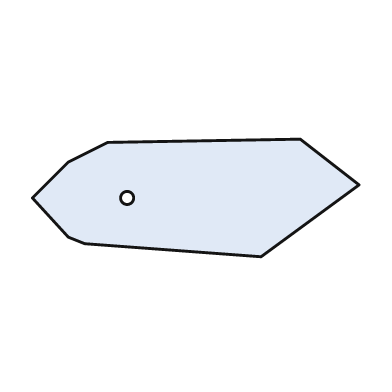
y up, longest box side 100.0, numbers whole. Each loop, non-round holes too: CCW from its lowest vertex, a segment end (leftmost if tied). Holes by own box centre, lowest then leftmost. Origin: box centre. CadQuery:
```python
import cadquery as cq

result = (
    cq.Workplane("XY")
    .moveTo(20.0, -18.0)
    .lineTo(50.0, 4.0)
    .lineTo(32.0, 18.0)
    .lineTo(-27.0, 17.0)
    .lineTo(-39.0, 11.0)
    .lineTo(-50.0, 0.0)
    .lineTo(-39.0, -12.0)
    .lineTo(-34.0, -14.0)
    .close()
    .moveTo(-21.0, 0.0)
    .circle(2.0)
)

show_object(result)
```